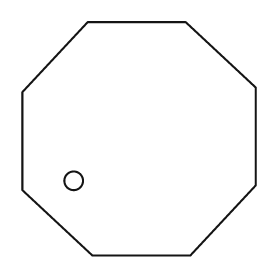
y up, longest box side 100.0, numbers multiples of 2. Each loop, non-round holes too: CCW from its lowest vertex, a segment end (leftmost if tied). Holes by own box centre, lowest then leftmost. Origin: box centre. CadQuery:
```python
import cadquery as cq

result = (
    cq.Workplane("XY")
    .moveTo(-20.0, -50.0)
    .lineTo(22.0, -50.0)
    .lineTo(50.0, -20.0)
    .lineTo(50.0, 22.0)
    .lineTo(20.0, 50.0)
    .lineTo(-22.0, 50.0)
    .lineTo(-50.0, 20.0)
    .lineTo(-50.0, -22.0)
    .close()
    .moveTo(-28.0, -18.0)
    .circle(4.0)
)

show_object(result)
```